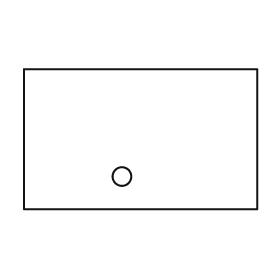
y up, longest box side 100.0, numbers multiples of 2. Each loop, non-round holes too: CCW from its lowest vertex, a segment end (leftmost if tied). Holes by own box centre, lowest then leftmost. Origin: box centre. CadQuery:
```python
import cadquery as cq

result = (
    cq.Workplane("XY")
    .moveTo(-50.0, -30.0)
    .lineTo(50.0, -30.0)
    .lineTo(50.0, 30.0)
    .lineTo(-50.0, 30.0)
    .close()
    .moveTo(-8.0, -16.0)
    .circle(4.0)
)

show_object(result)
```